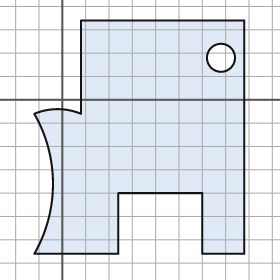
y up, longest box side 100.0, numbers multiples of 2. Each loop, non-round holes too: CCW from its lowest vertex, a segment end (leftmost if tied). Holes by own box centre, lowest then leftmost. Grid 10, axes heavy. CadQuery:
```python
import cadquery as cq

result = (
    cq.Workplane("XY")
    .moveTo(-12.0, -66.0)
    .lineTo(24.0, -66.0)
    .lineTo(24.0, -40.0)
    .lineTo(60.0, -40.0)
    .lineTo(60.0, -66.0)
    .lineTo(78.0, -66.0)
    .lineTo(78.0, 34.0)
    .lineTo(8.0, 34.0)
    .lineTo(8.0, -6.0)
    .threePointArc((-2.0, -4.0), (-12.0, -6.0))
    .threePointArc((-4.0, -36.0), (-12.0, -66.0))
    .close()
    .moveTo(68.0, 18.0)
    .circle(6.0)
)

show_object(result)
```